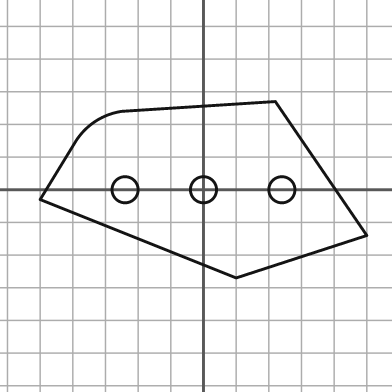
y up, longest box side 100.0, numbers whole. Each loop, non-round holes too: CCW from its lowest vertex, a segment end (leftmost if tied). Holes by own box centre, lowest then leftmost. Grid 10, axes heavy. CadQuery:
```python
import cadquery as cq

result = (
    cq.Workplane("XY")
    .moveTo(10.0, -27.0)
    .lineTo(50.0, -14.0)
    .lineTo(22.0, 27.0)
    .lineTo(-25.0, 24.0)
    .threePointArc((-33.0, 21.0), (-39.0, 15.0))
    .lineTo(-50.0, -3.0)
    .close()
    .moveTo(-24.0, 0.0)
    .circle(4.0)
    .moveTo(0.0, 0.0)
    .circle(4.0)
    .moveTo(24.0, 0.0)
    .circle(4.0)
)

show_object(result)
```